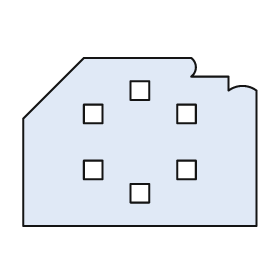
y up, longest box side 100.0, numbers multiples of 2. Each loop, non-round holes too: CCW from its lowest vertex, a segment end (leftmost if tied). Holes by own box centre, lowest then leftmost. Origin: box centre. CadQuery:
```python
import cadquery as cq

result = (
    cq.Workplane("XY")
    .moveTo(-50.0, -36.0)
    .lineTo(50.0, -36.0)
    .lineTo(50.0, 22.0)
    .threePointArc((44.0, 24.0), (38.0, 22.0))
    .lineTo(38.0, 28.0)
    .lineTo(22.0, 28.0)
    .threePointArc((24.0, 32.0), (22.0, 36.0))
    .lineTo(-24.0, 36.0)
    .lineTo(-50.0, 10.0)
    .close()
    .moveTo(-4.0, -26.0)
    .lineTo(4.0, -26.0)
    .lineTo(4.0, -18.0)
    .lineTo(-4.0, -18.0)
    .close()
    .moveTo(-24.0, -16.0)
    .lineTo(-16.0, -16.0)
    .lineTo(-16.0, -8.0)
    .lineTo(-24.0, -8.0)
    .close()
    .moveTo(16.0, -16.0)
    .lineTo(24.0, -16.0)
    .lineTo(24.0, -8.0)
    .lineTo(16.0, -8.0)
    .close()
    .moveTo(-24.0, 8.0)
    .lineTo(-16.0, 8.0)
    .lineTo(-16.0, 16.0)
    .lineTo(-24.0, 16.0)
    .close()
    .moveTo(16.0, 8.0)
    .lineTo(24.0, 8.0)
    .lineTo(24.0, 16.0)
    .lineTo(16.0, 16.0)
    .close()
    .moveTo(-4.0, 18.0)
    .lineTo(4.0, 18.0)
    .lineTo(4.0, 26.0)
    .lineTo(-4.0, 26.0)
    .close()
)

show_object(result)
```